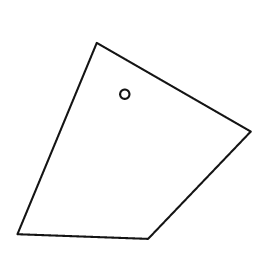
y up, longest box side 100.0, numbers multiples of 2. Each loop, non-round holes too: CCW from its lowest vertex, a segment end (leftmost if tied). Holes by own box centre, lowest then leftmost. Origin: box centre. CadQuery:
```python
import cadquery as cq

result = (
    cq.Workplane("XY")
    .moveTo(6.0, -42.0)
    .lineTo(50.0, 4.0)
    .lineTo(-16.0, 42.0)
    .lineTo(-50.0, -40.0)
    .close()
    .moveTo(-4.0, 20.0)
    .circle(2.0)
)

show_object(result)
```